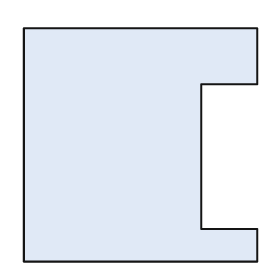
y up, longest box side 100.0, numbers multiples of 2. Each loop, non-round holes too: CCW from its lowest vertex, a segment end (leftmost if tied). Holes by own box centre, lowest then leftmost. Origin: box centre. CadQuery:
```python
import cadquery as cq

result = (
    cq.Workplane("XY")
    .moveTo(-50.0, -50.0)
    .lineTo(50.0, -50.0)
    .lineTo(50.0, -36.0)
    .lineTo(26.0, -36.0)
    .lineTo(26.0, 26.0)
    .lineTo(50.0, 26.0)
    .lineTo(50.0, 50.0)
    .lineTo(-50.0, 50.0)
    .close()
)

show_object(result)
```